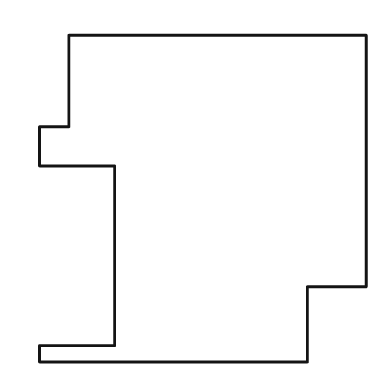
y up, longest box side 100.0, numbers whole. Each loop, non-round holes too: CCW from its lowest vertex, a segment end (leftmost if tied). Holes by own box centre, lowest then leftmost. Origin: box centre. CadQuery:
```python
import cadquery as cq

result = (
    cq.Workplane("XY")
    .moveTo(-50.0, -50.0)
    .lineTo(32.0, -50.0)
    .lineTo(32.0, -27.0)
    .lineTo(50.0, -27.0)
    .lineTo(50.0, 50.0)
    .lineTo(-41.0, 50.0)
    .lineTo(-41.0, 22.0)
    .lineTo(-50.0, 22.0)
    .lineTo(-50.0, 10.0)
    .lineTo(-27.0, 10.0)
    .lineTo(-27.0, -45.0)
    .lineTo(-50.0, -45.0)
    .close()
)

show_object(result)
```